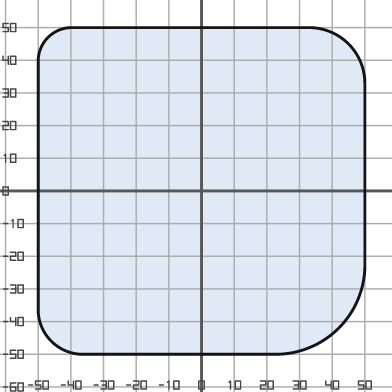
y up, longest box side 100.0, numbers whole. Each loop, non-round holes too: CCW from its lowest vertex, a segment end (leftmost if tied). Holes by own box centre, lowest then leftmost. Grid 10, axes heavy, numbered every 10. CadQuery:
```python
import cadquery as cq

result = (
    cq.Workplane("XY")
    .moveTo(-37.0, -50.0)
    .lineTo(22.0, -50.0)
    .threePointArc((42.0, -42.0), (50.0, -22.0))
    .lineTo(50.0, 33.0)
    .threePointArc((45.0, 45.0), (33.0, 50.0))
    .lineTo(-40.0, 50.0)
    .threePointArc((-47.0, 47.0), (-50.0, 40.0))
    .lineTo(-50.0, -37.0)
    .threePointArc((-46.0, -46.0), (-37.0, -50.0))
    .close()
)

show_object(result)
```